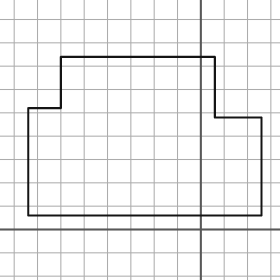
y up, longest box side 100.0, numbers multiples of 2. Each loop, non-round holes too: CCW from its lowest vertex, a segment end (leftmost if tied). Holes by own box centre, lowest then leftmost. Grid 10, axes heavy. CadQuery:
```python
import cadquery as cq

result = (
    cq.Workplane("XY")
    .moveTo(-74.0, 6.0)
    .lineTo(26.0, 6.0)
    .lineTo(26.0, 48.0)
    .lineTo(6.0, 48.0)
    .lineTo(6.0, 74.0)
    .lineTo(-60.0, 74.0)
    .lineTo(-60.0, 52.0)
    .lineTo(-74.0, 52.0)
    .close()
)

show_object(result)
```